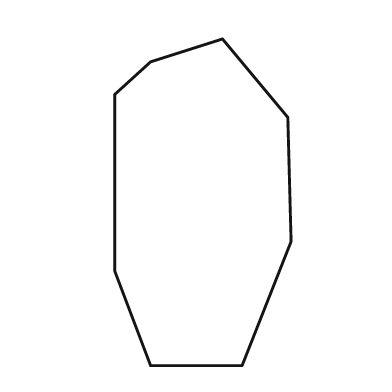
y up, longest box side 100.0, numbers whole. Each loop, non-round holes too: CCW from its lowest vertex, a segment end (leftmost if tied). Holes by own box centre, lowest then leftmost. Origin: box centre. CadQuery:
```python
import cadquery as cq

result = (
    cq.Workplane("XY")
    .moveTo(-16.0, -50.0)
    .lineTo(12.0, -50.0)
    .lineTo(27.0, -12.0)
    .lineTo(26.0, 26.0)
    .lineTo(6.0, 50.0)
    .lineTo(-16.0, 43.0)
    .lineTo(-27.0, 33.0)
    .lineTo(-27.0, -21.0)
    .close()
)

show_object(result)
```